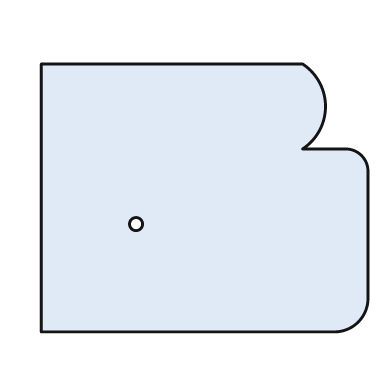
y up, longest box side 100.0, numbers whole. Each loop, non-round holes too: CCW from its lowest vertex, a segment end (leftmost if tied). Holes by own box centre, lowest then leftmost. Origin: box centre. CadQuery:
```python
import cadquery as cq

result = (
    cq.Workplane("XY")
    .moveTo(-50.0, -41.0)
    .lineTo(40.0, -41.0)
    .threePointArc((47.0, -38.0), (50.0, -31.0))
    .lineTo(50.0, 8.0)
    .threePointArc((48.0, 13.0), (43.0, 15.0))
    .lineTo(30.0, 15.0)
    .threePointArc((37.0, 28.0), (30.0, 41.0))
    .lineTo(-50.0, 41.0)
    .close()
    .moveTo(-21.0, -8.0)
    .circle(2.0)
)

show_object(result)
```